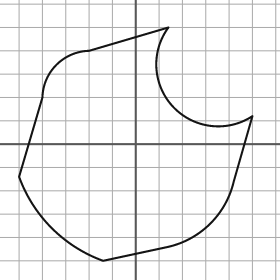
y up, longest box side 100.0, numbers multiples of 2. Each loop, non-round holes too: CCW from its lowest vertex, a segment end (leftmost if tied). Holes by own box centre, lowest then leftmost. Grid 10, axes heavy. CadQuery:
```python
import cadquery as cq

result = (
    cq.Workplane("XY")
    .moveTo(-14.0, -50.0)
    .lineTo(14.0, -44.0)
    .threePointArc((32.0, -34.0), (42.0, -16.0))
    .lineTo(50.0, 12.0)
    .threePointArc((16.0, 16.0), (14.0, 50.0))
    .lineTo(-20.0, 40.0)
    .threePointArc((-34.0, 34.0), (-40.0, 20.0))
    .lineTo(-50.0, -14.0)
    .threePointArc((-36.0, -36.0), (-14.0, -50.0))
    .close()
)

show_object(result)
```